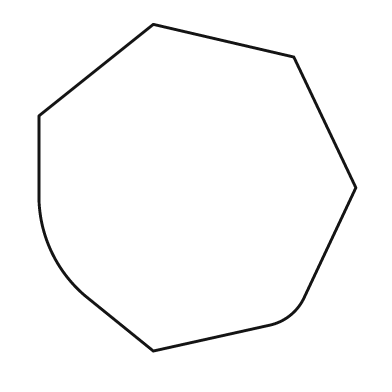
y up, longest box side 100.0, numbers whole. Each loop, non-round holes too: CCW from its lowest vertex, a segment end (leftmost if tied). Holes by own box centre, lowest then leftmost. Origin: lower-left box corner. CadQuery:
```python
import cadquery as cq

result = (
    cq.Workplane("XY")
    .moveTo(35.0, 0.0)
    .lineTo(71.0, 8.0)
    .threePointArc((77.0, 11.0), (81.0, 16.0))
    .lineTo(97.0, 50.0)
    .lineTo(78.0, 90.0)
    .lineTo(35.0, 100.0)
    .lineTo(0.0, 72.0)
    .lineTo(0.0, 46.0)
    .threePointArc((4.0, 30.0), (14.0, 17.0))
    .close()
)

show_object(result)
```